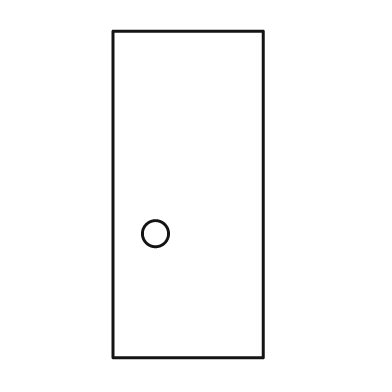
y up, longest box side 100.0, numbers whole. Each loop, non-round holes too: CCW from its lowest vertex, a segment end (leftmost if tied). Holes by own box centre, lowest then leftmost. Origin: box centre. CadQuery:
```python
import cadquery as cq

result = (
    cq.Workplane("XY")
    .moveTo(-23.0, -50.0)
    .lineTo(23.0, -50.0)
    .lineTo(23.0, 50.0)
    .lineTo(-23.0, 50.0)
    .close()
    .moveTo(-10.0, -12.0)
    .circle(4.0)
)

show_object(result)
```